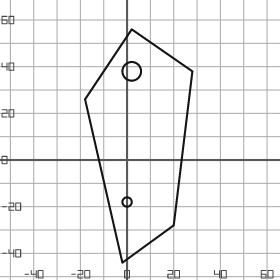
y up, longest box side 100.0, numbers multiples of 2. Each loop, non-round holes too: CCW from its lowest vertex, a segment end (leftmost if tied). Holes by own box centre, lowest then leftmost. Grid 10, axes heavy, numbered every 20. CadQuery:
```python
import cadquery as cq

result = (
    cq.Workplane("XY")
    .moveTo(-2.0, -44.0)
    .lineTo(20.0, -28.0)
    .lineTo(28.0, 38.0)
    .lineTo(2.0, 56.0)
    .lineTo(-18.0, 26.0)
    .close()
    .moveTo(0.0, -18.0)
    .circle(2.0)
    .moveTo(2.0, 38.0)
    .circle(4.0)
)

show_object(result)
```